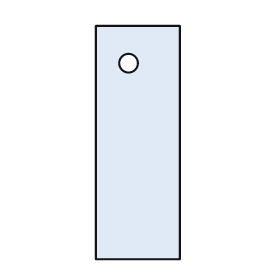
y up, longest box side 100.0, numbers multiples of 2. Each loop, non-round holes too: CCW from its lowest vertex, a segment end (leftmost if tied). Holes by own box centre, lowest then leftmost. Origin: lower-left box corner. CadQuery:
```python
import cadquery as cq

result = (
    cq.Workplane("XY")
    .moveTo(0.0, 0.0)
    .lineTo(36.0, 0.0)
    .lineTo(36.0, 100.0)
    .lineTo(0.0, 100.0)
    .close()
    .moveTo(14.0, 84.0)
    .circle(4.0)
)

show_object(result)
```